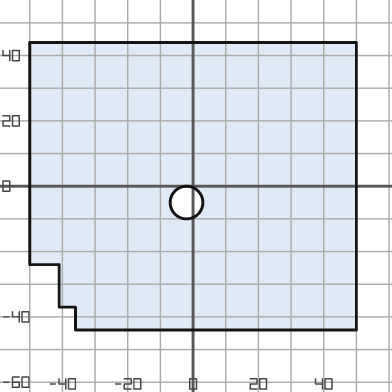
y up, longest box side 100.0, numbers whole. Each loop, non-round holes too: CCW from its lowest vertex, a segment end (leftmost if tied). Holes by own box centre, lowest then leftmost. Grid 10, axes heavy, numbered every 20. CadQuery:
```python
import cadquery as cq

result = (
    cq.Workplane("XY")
    .moveTo(-36.0, -44.0)
    .lineTo(50.0, -44.0)
    .lineTo(50.0, 44.0)
    .lineTo(-50.0, 44.0)
    .lineTo(-50.0, -24.0)
    .lineTo(-41.0, -24.0)
    .lineTo(-41.0, -37.0)
    .lineTo(-36.0, -37.0)
    .close()
    .moveTo(-2.0, -5.0)
    .circle(5.0)
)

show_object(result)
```